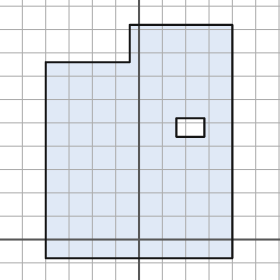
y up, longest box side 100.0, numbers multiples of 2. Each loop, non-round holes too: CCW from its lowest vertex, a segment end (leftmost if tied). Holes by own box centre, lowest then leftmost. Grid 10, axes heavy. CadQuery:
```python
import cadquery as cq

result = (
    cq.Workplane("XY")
    .moveTo(-40.0, -8.0)
    .lineTo(40.0, -8.0)
    .lineTo(40.0, 92.0)
    .lineTo(-4.0, 92.0)
    .lineTo(-4.0, 76.0)
    .lineTo(-40.0, 76.0)
    .close()
    .moveTo(16.0, 44.0)
    .lineTo(28.0, 44.0)
    .lineTo(28.0, 52.0)
    .lineTo(16.0, 52.0)
    .close()
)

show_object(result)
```